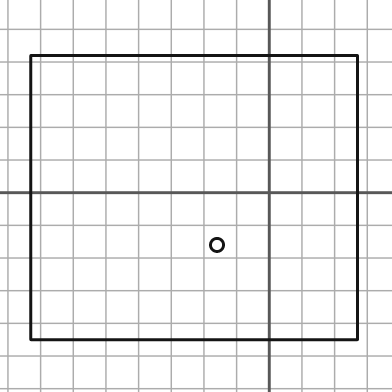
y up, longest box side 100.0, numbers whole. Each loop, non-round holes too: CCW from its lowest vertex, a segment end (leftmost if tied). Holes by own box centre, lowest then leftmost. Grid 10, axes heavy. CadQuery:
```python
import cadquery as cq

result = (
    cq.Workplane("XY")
    .moveTo(-73.0, -45.0)
    .lineTo(27.0, -45.0)
    .lineTo(27.0, 42.0)
    .lineTo(-73.0, 42.0)
    .close()
    .moveTo(-16.0, -16.0)
    .circle(2.0)
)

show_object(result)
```